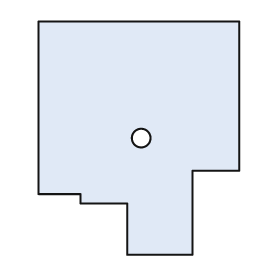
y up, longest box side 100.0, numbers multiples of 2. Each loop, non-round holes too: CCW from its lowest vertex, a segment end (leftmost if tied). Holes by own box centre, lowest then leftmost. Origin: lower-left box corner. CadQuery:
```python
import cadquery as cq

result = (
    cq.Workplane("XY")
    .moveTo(38.0, 0.0)
    .lineTo(66.0, 0.0)
    .lineTo(66.0, 36.0)
    .lineTo(86.0, 36.0)
    .lineTo(86.0, 100.0)
    .lineTo(0.0, 100.0)
    .lineTo(0.0, 26.0)
    .lineTo(18.0, 26.0)
    .lineTo(18.0, 22.0)
    .lineTo(38.0, 22.0)
    .close()
    .moveTo(44.0, 50.0)
    .circle(4.0)
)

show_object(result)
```